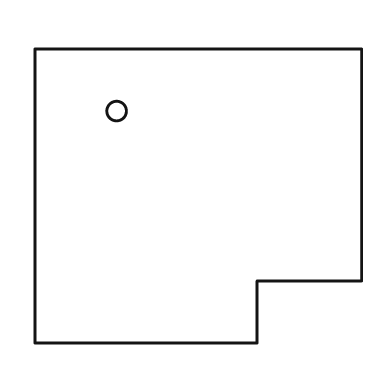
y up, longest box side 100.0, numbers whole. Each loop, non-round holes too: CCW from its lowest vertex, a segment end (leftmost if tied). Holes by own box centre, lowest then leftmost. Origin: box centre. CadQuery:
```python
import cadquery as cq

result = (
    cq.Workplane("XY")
    .moveTo(-50.0, -45.0)
    .lineTo(18.0, -45.0)
    .lineTo(18.0, -26.0)
    .lineTo(50.0, -26.0)
    .lineTo(50.0, 45.0)
    .lineTo(-50.0, 45.0)
    .close()
    .moveTo(-25.0, 26.0)
    .circle(3.0)
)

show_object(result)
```